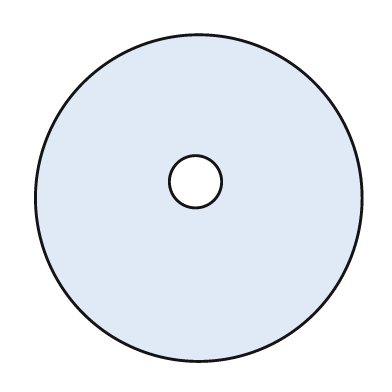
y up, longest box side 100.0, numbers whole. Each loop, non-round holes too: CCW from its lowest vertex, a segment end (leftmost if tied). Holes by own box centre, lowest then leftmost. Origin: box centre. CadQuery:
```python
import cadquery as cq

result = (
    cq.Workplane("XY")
    .moveTo(0.0, 0.0)
    .circle(50.0)
    .moveTo(-1.0, 5.0)
    .circle(8.0)
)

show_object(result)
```